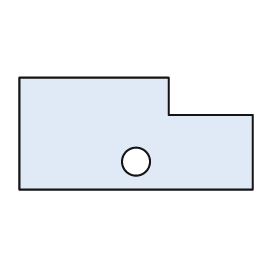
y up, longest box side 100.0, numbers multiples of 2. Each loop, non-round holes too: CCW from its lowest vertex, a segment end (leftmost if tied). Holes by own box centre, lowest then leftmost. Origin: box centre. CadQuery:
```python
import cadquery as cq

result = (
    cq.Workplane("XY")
    .moveTo(-50.0, -24.0)
    .lineTo(50.0, -24.0)
    .lineTo(50.0, 8.0)
    .lineTo(14.0, 8.0)
    .lineTo(14.0, 24.0)
    .lineTo(-50.0, 24.0)
    .close()
    .moveTo(0.0, -12.0)
    .circle(6.0)
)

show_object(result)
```